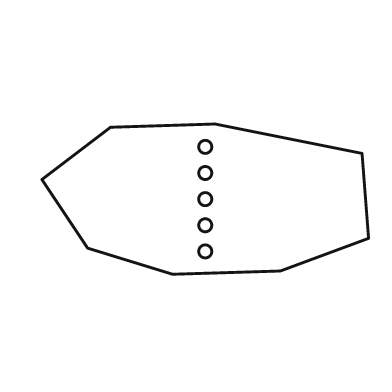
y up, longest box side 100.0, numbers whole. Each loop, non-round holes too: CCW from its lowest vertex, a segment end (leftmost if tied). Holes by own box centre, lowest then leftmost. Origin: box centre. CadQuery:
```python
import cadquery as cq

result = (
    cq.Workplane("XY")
    .moveTo(-10.0, -23.0)
    .lineTo(23.0, -22.0)
    .lineTo(50.0, -12.0)
    .lineTo(48.0, 14.0)
    .lineTo(3.0, 23.0)
    .lineTo(-29.0, 22.0)
    .lineTo(-50.0, 6.0)
    .lineTo(-36.0, -15.0)
    .close()
    .moveTo(0.0, -16.0)
    .circle(2.0)
    .moveTo(0.0, -8.0)
    .circle(2.0)
    .moveTo(0.0, 0.0)
    .circle(2.0)
    .moveTo(0.0, 8.0)
    .circle(2.0)
    .moveTo(0.0, 16.0)
    .circle(2.0)
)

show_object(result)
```